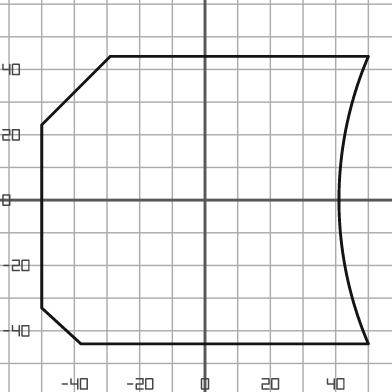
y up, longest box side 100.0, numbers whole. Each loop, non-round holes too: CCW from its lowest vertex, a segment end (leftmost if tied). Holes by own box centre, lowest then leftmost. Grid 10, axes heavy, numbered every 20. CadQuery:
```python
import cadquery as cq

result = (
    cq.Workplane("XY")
    .moveTo(-38.0, -44.0)
    .lineTo(50.0, -44.0)
    .threePointArc((41.0, 0.0), (50.0, 44.0))
    .lineTo(-29.0, 44.0)
    .lineTo(-50.0, 23.0)
    .lineTo(-50.0, -33.0)
    .close()
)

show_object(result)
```